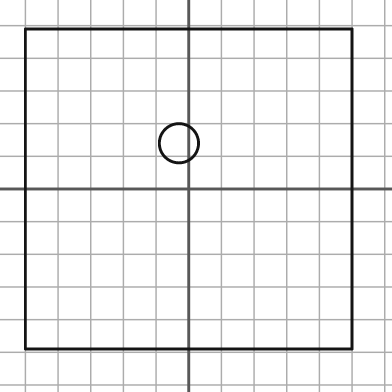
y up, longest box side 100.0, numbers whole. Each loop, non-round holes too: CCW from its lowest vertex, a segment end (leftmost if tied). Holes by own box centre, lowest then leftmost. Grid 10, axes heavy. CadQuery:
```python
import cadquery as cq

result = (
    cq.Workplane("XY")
    .moveTo(-50.0, -49.0)
    .lineTo(50.0, -49.0)
    .lineTo(50.0, 49.0)
    .lineTo(-50.0, 49.0)
    .close()
    .moveTo(-3.0, 14.0)
    .circle(6.0)
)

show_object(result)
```